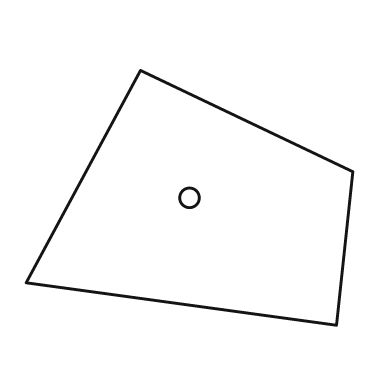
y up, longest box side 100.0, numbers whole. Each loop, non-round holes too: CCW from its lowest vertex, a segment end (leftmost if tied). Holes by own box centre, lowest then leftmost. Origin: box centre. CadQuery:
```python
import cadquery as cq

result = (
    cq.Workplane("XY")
    .moveTo(45.0, -39.0)
    .lineTo(50.0, 8.0)
    .lineTo(-15.0, 39.0)
    .lineTo(-50.0, -26.0)
    .close()
    .moveTo(0.0, 0.0)
    .circle(3.0)
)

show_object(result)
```